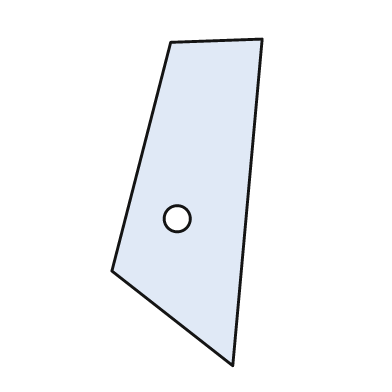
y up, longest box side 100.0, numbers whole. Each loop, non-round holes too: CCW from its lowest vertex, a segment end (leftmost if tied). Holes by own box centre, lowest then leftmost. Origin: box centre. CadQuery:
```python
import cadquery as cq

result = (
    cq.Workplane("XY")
    .moveTo(14.0, -50.0)
    .lineTo(23.0, 50.0)
    .lineTo(-5.0, 49.0)
    .lineTo(-23.0, -21.0)
    .close()
    .moveTo(-3.0, -5.0)
    .circle(4.0)
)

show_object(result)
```